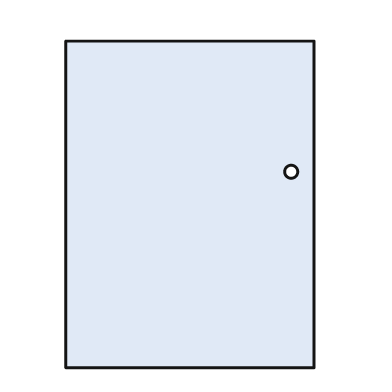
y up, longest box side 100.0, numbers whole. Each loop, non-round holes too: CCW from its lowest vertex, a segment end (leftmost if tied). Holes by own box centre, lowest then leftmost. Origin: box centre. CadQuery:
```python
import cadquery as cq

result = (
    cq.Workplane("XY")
    .moveTo(-38.0, -50.0)
    .lineTo(38.0, -50.0)
    .lineTo(38.0, 50.0)
    .lineTo(-38.0, 50.0)
    .close()
    .moveTo(31.0, 10.0)
    .circle(2.0)
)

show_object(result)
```